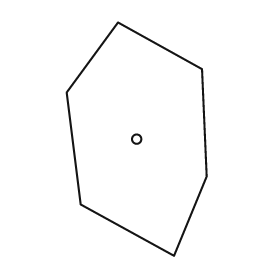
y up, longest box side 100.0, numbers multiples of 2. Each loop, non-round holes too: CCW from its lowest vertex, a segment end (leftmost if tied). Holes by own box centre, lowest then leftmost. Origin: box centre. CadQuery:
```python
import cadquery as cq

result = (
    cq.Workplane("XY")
    .moveTo(16.0, -50.0)
    .lineTo(30.0, -16.0)
    .lineTo(28.0, 30.0)
    .lineTo(-8.0, 50.0)
    .lineTo(-30.0, 20.0)
    .lineTo(-24.0, -28.0)
    .close()
    .moveTo(0.0, 0.0)
    .circle(2.0)
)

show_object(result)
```